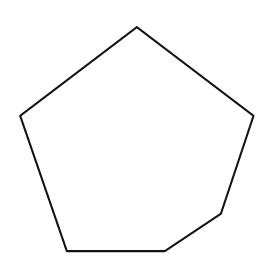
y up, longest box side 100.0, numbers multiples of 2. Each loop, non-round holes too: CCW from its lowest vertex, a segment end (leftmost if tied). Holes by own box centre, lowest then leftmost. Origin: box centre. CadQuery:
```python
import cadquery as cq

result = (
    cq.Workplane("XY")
    .moveTo(-30.0, -48.0)
    .lineTo(12.0, -48.0)
    .lineTo(36.0, -32.0)
    .lineTo(50.0, 10.0)
    .lineTo(0.0, 48.0)
    .lineTo(-50.0, 10.0)
    .close()
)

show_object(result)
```